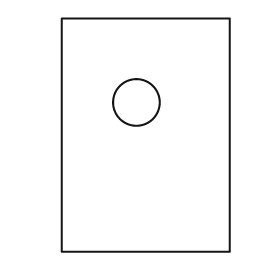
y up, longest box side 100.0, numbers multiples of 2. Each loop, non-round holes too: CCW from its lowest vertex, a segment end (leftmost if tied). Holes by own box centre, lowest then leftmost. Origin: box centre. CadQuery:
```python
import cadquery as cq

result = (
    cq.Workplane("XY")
    .moveTo(-36.0, -50.0)
    .lineTo(36.0, -50.0)
    .lineTo(36.0, 50.0)
    .lineTo(-36.0, 50.0)
    .close()
    .moveTo(-4.0, 14.0)
    .circle(10.0)
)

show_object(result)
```